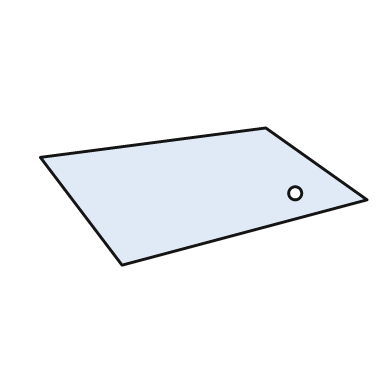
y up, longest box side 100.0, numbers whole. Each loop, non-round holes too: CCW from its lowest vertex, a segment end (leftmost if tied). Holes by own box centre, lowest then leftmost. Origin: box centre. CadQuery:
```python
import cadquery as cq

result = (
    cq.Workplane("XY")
    .moveTo(-25.0, -21.0)
    .lineTo(50.0, -1.0)
    .lineTo(19.0, 21.0)
    .lineTo(-50.0, 12.0)
    .close()
    .moveTo(28.0, 1.0)
    .circle(2.0)
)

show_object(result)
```